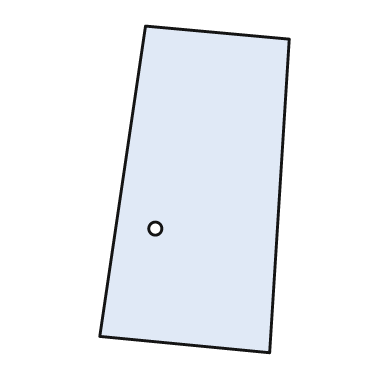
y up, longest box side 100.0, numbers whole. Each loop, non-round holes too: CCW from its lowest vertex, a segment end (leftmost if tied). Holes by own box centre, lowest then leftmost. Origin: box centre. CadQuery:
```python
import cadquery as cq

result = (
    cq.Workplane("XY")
    .moveTo(23.0, -50.0)
    .lineTo(29.0, 46.0)
    .lineTo(-15.0, 50.0)
    .lineTo(-29.0, -45.0)
    .close()
    .moveTo(-12.0, -12.0)
    .circle(2.0)
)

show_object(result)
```